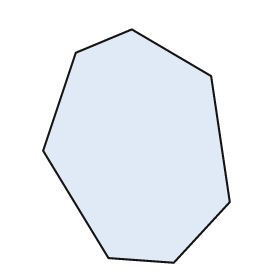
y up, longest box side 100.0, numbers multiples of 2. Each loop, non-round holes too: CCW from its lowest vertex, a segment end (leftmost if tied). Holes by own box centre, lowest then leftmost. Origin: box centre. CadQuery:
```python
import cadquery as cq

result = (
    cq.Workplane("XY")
    .moveTo(16.0, -50.0)
    .lineTo(40.0, -24.0)
    .lineTo(32.0, 30.0)
    .lineTo(-2.0, 50.0)
    .lineTo(-26.0, 40.0)
    .lineTo(-40.0, -2.0)
    .lineTo(-12.0, -48.0)
    .close()
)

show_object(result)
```